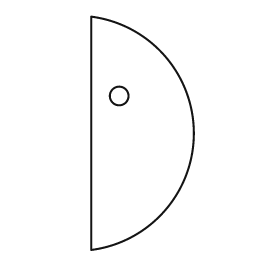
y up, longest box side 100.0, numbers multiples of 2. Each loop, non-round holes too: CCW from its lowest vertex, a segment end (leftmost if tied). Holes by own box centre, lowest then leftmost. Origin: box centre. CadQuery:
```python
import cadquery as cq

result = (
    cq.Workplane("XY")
    .moveTo(-22.0, -50.0)
    .threePointArc((22.0, 0.0), (-22.0, 50.0))
    .close()
    .moveTo(-10.0, 16.0)
    .circle(4.0)
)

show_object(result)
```